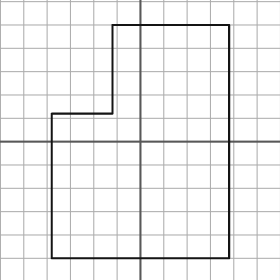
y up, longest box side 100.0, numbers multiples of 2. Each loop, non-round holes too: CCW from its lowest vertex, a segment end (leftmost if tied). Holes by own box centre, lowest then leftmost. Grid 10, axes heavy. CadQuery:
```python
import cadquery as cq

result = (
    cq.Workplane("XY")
    .moveTo(-38.0, -50.0)
    .lineTo(38.0, -50.0)
    .lineTo(38.0, 50.0)
    .lineTo(-12.0, 50.0)
    .lineTo(-12.0, 12.0)
    .lineTo(-38.0, 12.0)
    .close()
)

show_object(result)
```